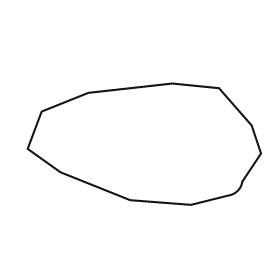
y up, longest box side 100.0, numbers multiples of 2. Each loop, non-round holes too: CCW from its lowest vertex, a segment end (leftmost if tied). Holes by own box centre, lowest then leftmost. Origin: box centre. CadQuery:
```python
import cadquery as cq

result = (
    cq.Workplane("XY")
    .moveTo(20.0, -26.0)
    .lineTo(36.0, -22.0)
    .threePointArc((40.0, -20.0), (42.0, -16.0))
    .lineTo(50.0, -4.0)
    .lineTo(46.0, 8.0)
    .lineTo(32.0, 24.0)
    .lineTo(12.0, 26.0)
    .lineTo(-24.0, 22.0)
    .lineTo(-44.0, 14.0)
    .lineTo(-50.0, -2.0)
    .lineTo(-36.0, -12.0)
    .lineTo(-6.0, -24.0)
    .close()
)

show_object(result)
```